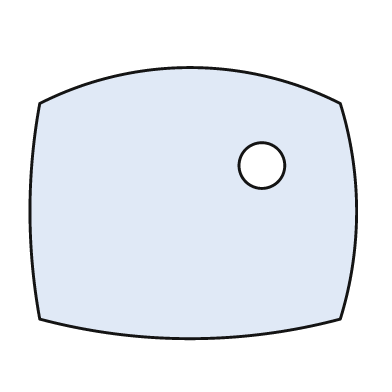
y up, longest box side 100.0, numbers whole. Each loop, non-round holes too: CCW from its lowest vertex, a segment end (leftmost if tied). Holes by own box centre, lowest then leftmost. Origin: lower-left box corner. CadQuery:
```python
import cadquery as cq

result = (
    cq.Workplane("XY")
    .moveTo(3.0, 6.0)
    .threePointArc((49.0, 0.0), (95.0, 6.0))
    .threePointArc((100.0, 39.0), (95.0, 72.0))
    .threePointArc((49.0, 83.0), (3.0, 72.0))
    .threePointArc((0.0, 39.0), (3.0, 6.0))
    .close()
    .moveTo(71.0, 53.0)
    .circle(7.0)
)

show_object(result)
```